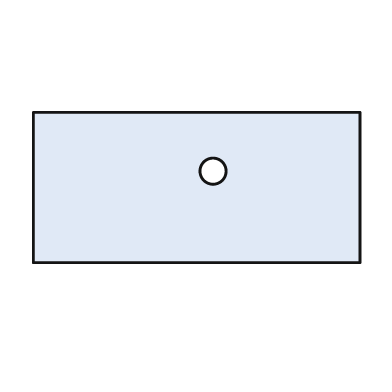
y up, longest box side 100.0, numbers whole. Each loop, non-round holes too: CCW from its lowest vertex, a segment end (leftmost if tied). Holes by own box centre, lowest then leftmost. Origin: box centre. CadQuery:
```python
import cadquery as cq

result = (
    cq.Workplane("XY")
    .moveTo(-50.0, -23.0)
    .lineTo(50.0, -23.0)
    .lineTo(50.0, 23.0)
    .lineTo(-50.0, 23.0)
    .close()
    .moveTo(5.0, 5.0)
    .circle(4.0)
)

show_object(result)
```